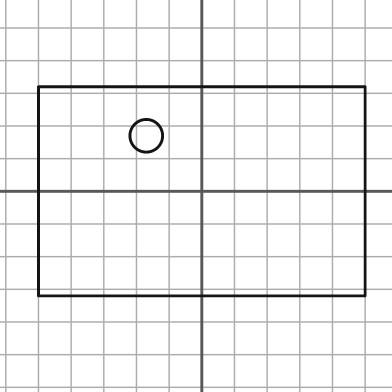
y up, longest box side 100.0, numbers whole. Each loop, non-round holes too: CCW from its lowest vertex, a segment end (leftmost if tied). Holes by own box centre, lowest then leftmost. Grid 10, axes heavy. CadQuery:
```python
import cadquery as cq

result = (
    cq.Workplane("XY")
    .moveTo(-50.0, -32.0)
    .lineTo(50.0, -32.0)
    .lineTo(50.0, 32.0)
    .lineTo(-50.0, 32.0)
    .close()
    .moveTo(-17.0, 17.0)
    .circle(5.0)
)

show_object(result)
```